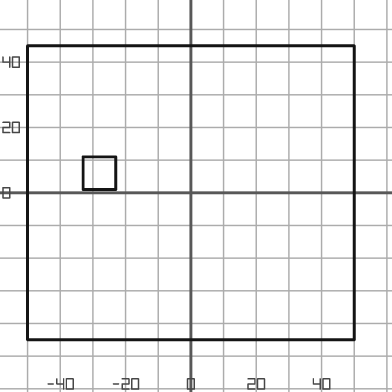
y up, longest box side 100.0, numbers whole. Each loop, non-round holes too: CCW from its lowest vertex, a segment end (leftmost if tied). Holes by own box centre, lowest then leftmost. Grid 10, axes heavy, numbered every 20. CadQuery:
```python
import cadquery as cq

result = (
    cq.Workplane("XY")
    .moveTo(-50.0, -45.0)
    .lineTo(50.0, -45.0)
    .lineTo(50.0, 45.0)
    .lineTo(-50.0, 45.0)
    .close()
    .moveTo(-33.0, 1.0)
    .lineTo(-23.0, 1.0)
    .lineTo(-23.0, 11.0)
    .lineTo(-33.0, 11.0)
    .close()
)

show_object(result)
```